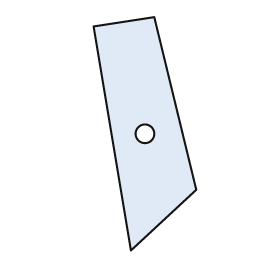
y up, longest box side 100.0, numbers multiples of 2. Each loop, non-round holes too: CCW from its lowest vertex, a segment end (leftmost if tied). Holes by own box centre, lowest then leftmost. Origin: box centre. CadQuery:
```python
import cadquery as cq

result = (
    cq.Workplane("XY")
    .moveTo(-6.0, -50.0)
    .lineTo(22.0, -24.0)
    .lineTo(4.0, 50.0)
    .lineTo(-22.0, 46.0)
    .close()
    .moveTo(0.0, 0.0)
    .circle(4.0)
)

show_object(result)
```